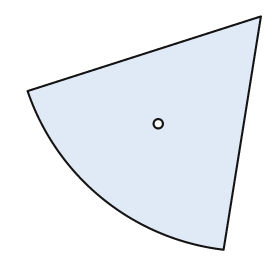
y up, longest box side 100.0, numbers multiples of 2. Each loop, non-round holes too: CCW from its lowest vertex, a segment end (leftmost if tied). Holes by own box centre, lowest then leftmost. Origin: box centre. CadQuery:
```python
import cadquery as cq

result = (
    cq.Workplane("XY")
    .moveTo(34.0, -50.0)
    .lineTo(50.0, 50.0)
    .lineTo(-50.0, 18.0)
    .threePointArc((-18.0, -28.0), (34.0, -50.0))
    .close()
    .moveTo(6.0, 4.0)
    .circle(2.0)
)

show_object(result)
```